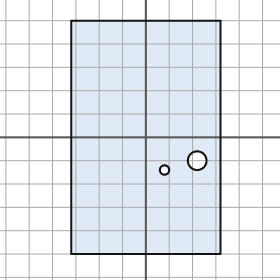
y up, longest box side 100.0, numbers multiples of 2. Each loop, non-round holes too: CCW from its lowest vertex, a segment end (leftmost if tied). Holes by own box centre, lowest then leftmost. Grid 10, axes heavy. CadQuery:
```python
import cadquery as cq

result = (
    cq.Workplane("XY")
    .moveTo(-32.0, -50.0)
    .lineTo(32.0, -50.0)
    .lineTo(32.0, 50.0)
    .lineTo(-32.0, 50.0)
    .close()
    .moveTo(8.0, -14.0)
    .circle(2.0)
    .moveTo(22.0, -10.0)
    .circle(4.0)
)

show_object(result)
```